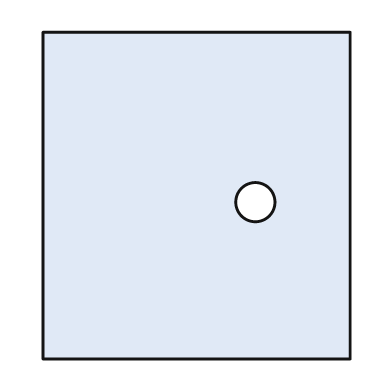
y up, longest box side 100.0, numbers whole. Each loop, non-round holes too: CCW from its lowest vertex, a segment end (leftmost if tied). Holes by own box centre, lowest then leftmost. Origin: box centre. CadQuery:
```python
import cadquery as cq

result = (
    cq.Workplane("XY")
    .moveTo(-47.0, -50.0)
    .lineTo(47.0, -50.0)
    .lineTo(47.0, 50.0)
    .lineTo(-47.0, 50.0)
    .close()
    .moveTo(18.0, -2.0)
    .circle(6.0)
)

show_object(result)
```